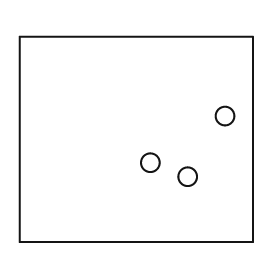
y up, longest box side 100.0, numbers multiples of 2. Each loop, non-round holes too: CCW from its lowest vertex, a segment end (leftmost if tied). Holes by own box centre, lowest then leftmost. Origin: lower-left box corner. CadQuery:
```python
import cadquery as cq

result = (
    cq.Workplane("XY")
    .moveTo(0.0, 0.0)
    .lineTo(100.0, 0.0)
    .lineTo(100.0, 88.0)
    .lineTo(0.0, 88.0)
    .close()
    .moveTo(72.0, 28.0)
    .circle(4.0)
    .moveTo(56.0, 34.0)
    .circle(4.0)
    .moveTo(88.0, 54.0)
    .circle(4.0)
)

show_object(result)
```